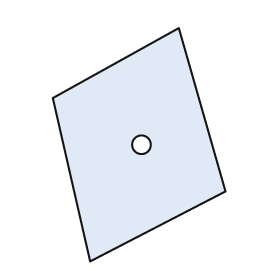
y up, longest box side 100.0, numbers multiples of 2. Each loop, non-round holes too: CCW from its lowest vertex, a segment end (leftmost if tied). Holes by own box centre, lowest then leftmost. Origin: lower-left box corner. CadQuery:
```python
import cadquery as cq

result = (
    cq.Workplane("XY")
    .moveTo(16.0, 0.0)
    .lineTo(74.0, 30.0)
    .lineTo(54.0, 100.0)
    .lineTo(0.0, 70.0)
    .close()
    .moveTo(38.0, 50.0)
    .circle(4.0)
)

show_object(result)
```